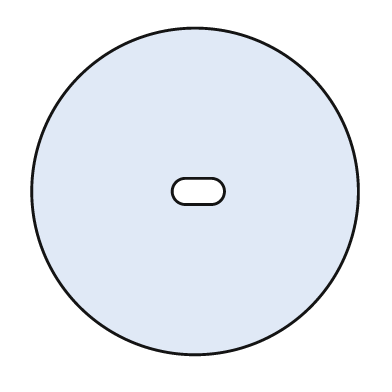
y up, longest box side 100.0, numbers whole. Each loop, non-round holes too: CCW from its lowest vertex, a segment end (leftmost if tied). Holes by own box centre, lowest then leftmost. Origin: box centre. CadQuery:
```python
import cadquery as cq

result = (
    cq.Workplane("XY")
    .moveTo(0.0, 0.0)
    .circle(50.0)
    .moveTo(-3.0, -4.0)
    .lineTo(5.0, -4.0)
    .threePointArc((9.0, 0.0), (5.0, 4.0))
    .lineTo(-3.0, 4.0)
    .threePointArc((-7.0, 0.0), (-3.0, -4.0))
    .close()
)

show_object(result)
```